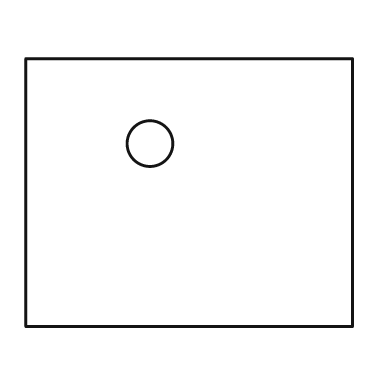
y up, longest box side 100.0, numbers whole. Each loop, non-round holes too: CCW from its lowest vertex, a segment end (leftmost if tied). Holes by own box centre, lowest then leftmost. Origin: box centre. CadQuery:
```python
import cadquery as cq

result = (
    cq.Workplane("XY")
    .moveTo(-50.0, -41.0)
    .lineTo(50.0, -41.0)
    .lineTo(50.0, 41.0)
    .lineTo(-50.0, 41.0)
    .close()
    .moveTo(-12.0, 15.0)
    .circle(7.0)
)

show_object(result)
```